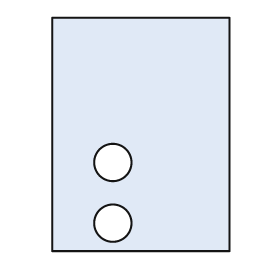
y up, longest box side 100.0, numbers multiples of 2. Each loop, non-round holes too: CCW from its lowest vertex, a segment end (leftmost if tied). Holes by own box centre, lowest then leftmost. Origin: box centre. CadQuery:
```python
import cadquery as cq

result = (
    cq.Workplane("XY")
    .moveTo(-38.0, -50.0)
    .lineTo(38.0, -50.0)
    .lineTo(38.0, 50.0)
    .lineTo(-38.0, 50.0)
    .close()
    .moveTo(-12.0, -38.0)
    .circle(8.0)
    .moveTo(-12.0, -12.0)
    .circle(8.0)
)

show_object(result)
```